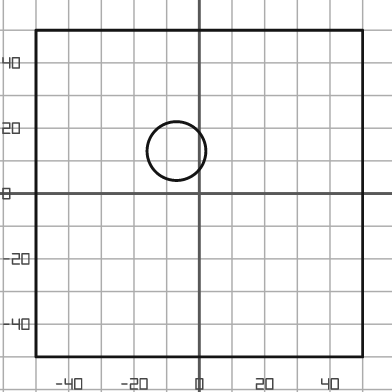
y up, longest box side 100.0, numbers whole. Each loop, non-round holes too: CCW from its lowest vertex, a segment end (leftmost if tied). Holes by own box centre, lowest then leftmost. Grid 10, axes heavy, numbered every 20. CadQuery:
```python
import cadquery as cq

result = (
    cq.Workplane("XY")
    .moveTo(-50.0, -50.0)
    .lineTo(50.0, -50.0)
    .lineTo(50.0, 50.0)
    .lineTo(-50.0, 50.0)
    .close()
    .moveTo(-7.0, 13.0)
    .circle(9.0)
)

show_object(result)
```